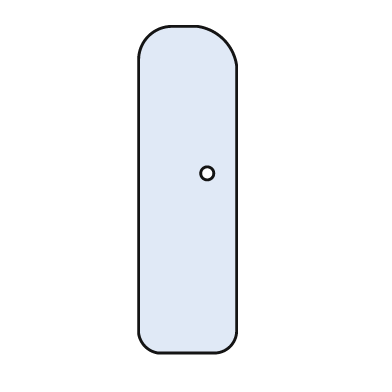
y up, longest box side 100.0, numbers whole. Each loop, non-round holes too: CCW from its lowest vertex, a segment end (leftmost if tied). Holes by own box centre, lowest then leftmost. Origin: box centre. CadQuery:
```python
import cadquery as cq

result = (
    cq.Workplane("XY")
    .moveTo(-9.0, -50.0)
    .lineTo(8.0, -50.0)
    .threePointArc((13.0, -48.0), (15.0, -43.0))
    .lineTo(15.0, 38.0)
    .threePointArc((11.0, 46.0), (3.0, 50.0))
    .lineTo(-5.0, 50.0)
    .threePointArc((-12.0, 47.0), (-15.0, 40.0))
    .lineTo(-15.0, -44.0)
    .threePointArc((-13.0, -48.0), (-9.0, -50.0))
    .close()
    .moveTo(6.0, 5.0)
    .circle(2.0)
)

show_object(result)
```